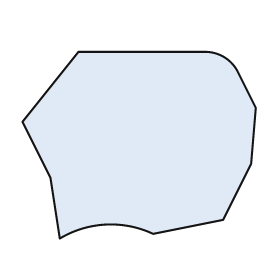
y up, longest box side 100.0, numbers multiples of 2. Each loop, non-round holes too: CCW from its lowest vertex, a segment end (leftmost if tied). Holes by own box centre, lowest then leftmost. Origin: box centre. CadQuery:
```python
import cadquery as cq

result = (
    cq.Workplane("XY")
    .moveTo(-34.0, -40.0)
    .threePointArc((-14.0, -34.0), (6.0, -38.0))
    .lineTo(36.0, -32.0)
    .lineTo(48.0, -8.0)
    .lineTo(50.0, 16.0)
    .lineTo(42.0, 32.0)
    .threePointArc((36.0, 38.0), (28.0, 40.0))
    .lineTo(-26.0, 40.0)
    .lineTo(-50.0, 10.0)
    .lineTo(-38.0, -14.0)
    .close()
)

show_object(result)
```